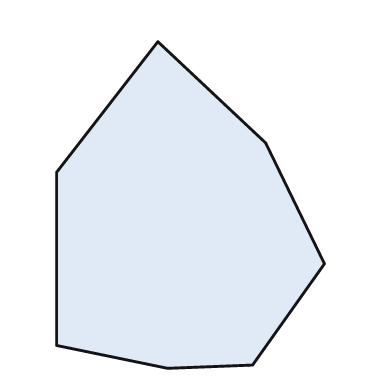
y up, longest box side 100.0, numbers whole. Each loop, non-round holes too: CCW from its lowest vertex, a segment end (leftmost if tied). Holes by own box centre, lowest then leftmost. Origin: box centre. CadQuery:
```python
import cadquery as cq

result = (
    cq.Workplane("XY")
    .moveTo(-7.0, -50.0)
    .lineTo(19.0, -49.0)
    .lineTo(41.0, -18.0)
    .lineTo(23.0, 19.0)
    .lineTo(-10.0, 50.0)
    .lineTo(-41.0, 10.0)
    .lineTo(-41.0, -43.0)
    .close()
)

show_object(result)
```